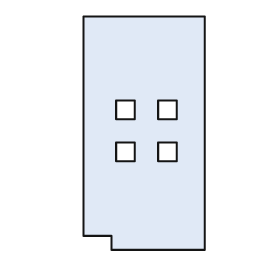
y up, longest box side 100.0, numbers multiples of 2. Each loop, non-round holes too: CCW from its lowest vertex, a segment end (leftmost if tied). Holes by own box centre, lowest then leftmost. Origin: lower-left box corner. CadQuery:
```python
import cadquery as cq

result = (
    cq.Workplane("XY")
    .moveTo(12.0, 0.0)
    .lineTo(52.0, 0.0)
    .lineTo(52.0, 100.0)
    .lineTo(0.0, 100.0)
    .lineTo(0.0, 6.0)
    .lineTo(12.0, 6.0)
    .close()
    .moveTo(14.0, 38.0)
    .lineTo(22.0, 38.0)
    .lineTo(22.0, 46.0)
    .lineTo(14.0, 46.0)
    .close()
    .moveTo(32.0, 38.0)
    .lineTo(40.0, 38.0)
    .lineTo(40.0, 46.0)
    .lineTo(32.0, 46.0)
    .close()
    .moveTo(14.0, 56.0)
    .lineTo(22.0, 56.0)
    .lineTo(22.0, 64.0)
    .lineTo(14.0, 64.0)
    .close()
    .moveTo(32.0, 56.0)
    .lineTo(40.0, 56.0)
    .lineTo(40.0, 64.0)
    .lineTo(32.0, 64.0)
    .close()
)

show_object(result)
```